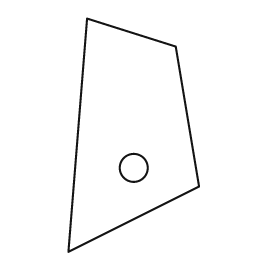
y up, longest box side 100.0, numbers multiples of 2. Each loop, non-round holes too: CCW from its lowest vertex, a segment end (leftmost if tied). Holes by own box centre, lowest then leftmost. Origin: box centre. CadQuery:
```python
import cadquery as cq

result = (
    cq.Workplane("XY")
    .moveTo(-28.0, -50.0)
    .lineTo(28.0, -22.0)
    .lineTo(18.0, 38.0)
    .lineTo(-20.0, 50.0)
    .close()
    .moveTo(0.0, -14.0)
    .circle(6.0)
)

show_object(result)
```